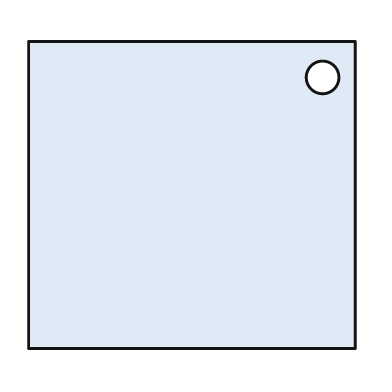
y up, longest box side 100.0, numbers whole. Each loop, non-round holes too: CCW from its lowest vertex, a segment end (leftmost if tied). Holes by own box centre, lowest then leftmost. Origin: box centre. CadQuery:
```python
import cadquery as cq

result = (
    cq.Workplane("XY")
    .moveTo(-50.0, -47.0)
    .lineTo(50.0, -47.0)
    .lineTo(50.0, 47.0)
    .lineTo(-50.0, 47.0)
    .close()
    .moveTo(40.0, 36.0)
    .circle(5.0)
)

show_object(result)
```